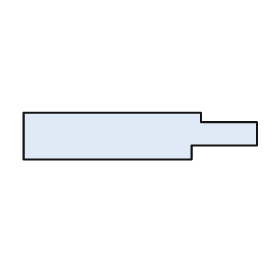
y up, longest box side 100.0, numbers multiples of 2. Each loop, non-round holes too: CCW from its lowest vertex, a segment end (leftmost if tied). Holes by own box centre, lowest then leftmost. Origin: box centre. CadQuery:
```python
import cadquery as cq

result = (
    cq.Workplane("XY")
    .moveTo(-50.0, -10.0)
    .lineTo(22.0, -10.0)
    .lineTo(22.0, -4.0)
    .lineTo(50.0, -4.0)
    .lineTo(50.0, 6.0)
    .lineTo(26.0, 6.0)
    .lineTo(26.0, 10.0)
    .lineTo(-50.0, 10.0)
    .close()
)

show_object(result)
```